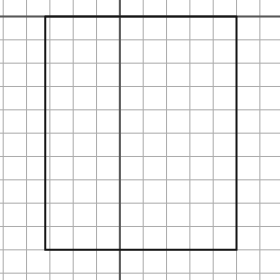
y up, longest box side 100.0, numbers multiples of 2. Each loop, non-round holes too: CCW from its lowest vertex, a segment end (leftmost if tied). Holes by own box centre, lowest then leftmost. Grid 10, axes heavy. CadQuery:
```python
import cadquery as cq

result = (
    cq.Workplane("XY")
    .moveTo(-32.0, -100.0)
    .lineTo(50.0, -100.0)
    .lineTo(50.0, 0.0)
    .lineTo(-32.0, 0.0)
    .close()
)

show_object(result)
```